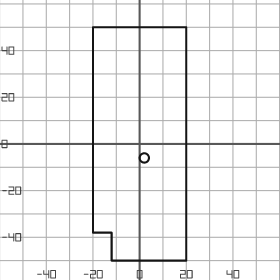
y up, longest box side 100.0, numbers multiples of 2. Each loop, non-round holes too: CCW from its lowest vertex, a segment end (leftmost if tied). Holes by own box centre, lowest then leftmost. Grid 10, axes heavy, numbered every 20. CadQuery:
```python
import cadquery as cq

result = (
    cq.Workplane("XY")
    .moveTo(-12.0, -50.0)
    .lineTo(20.0, -50.0)
    .lineTo(20.0, 50.0)
    .lineTo(-20.0, 50.0)
    .lineTo(-20.0, -38.0)
    .lineTo(-12.0, -38.0)
    .close()
    .moveTo(2.0, -6.0)
    .circle(2.0)
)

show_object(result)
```